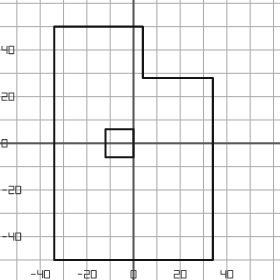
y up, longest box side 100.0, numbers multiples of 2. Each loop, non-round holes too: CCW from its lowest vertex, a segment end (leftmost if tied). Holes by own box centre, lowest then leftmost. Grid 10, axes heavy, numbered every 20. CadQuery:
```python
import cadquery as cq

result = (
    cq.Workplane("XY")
    .moveTo(-34.0, -50.0)
    .lineTo(34.0, -50.0)
    .lineTo(34.0, 28.0)
    .lineTo(4.0, 28.0)
    .lineTo(4.0, 50.0)
    .lineTo(-34.0, 50.0)
    .close()
    .moveTo(-12.0, -6.0)
    .lineTo(0.0, -6.0)
    .lineTo(0.0, 6.0)
    .lineTo(-12.0, 6.0)
    .close()
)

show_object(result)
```